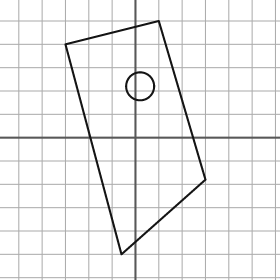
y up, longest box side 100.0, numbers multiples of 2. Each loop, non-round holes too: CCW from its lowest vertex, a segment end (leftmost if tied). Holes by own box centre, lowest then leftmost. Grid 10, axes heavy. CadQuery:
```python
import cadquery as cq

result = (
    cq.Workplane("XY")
    .moveTo(-6.0, -50.0)
    .lineTo(30.0, -18.0)
    .lineTo(10.0, 50.0)
    .lineTo(-30.0, 40.0)
    .close()
    .moveTo(2.0, 22.0)
    .circle(6.0)
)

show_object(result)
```